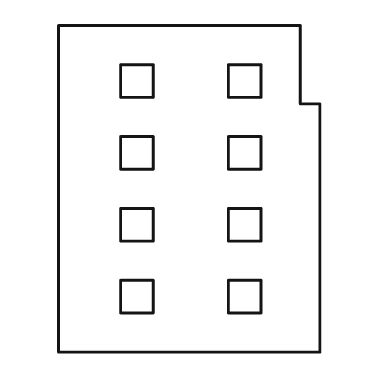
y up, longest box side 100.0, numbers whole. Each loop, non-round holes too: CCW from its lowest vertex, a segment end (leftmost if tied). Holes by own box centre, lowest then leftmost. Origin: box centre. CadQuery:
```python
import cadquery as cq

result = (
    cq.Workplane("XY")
    .moveTo(-40.0, -50.0)
    .lineTo(40.0, -50.0)
    .lineTo(40.0, 26.0)
    .lineTo(34.0, 26.0)
    .lineTo(34.0, 50.0)
    .lineTo(-40.0, 50.0)
    .close()
    .moveTo(-21.0, -38.0)
    .lineTo(-11.0, -38.0)
    .lineTo(-11.0, -28.0)
    .lineTo(-21.0, -28.0)
    .close()
    .moveTo(12.0, -38.0)
    .lineTo(22.0, -38.0)
    .lineTo(22.0, -28.0)
    .lineTo(12.0, -28.0)
    .close()
    .moveTo(-21.0, -16.0)
    .lineTo(-11.0, -16.0)
    .lineTo(-11.0, -6.0)
    .lineTo(-21.0, -6.0)
    .close()
    .moveTo(12.0, -16.0)
    .lineTo(22.0, -16.0)
    .lineTo(22.0, -6.0)
    .lineTo(12.0, -6.0)
    .close()
    .moveTo(-21.0, 6.0)
    .lineTo(-11.0, 6.0)
    .lineTo(-11.0, 16.0)
    .lineTo(-21.0, 16.0)
    .close()
    .moveTo(12.0, 6.0)
    .lineTo(22.0, 6.0)
    .lineTo(22.0, 16.0)
    .lineTo(12.0, 16.0)
    .close()
    .moveTo(-21.0, 28.0)
    .lineTo(-11.0, 28.0)
    .lineTo(-11.0, 38.0)
    .lineTo(-21.0, 38.0)
    .close()
    .moveTo(12.0, 28.0)
    .lineTo(22.0, 28.0)
    .lineTo(22.0, 38.0)
    .lineTo(12.0, 38.0)
    .close()
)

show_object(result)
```